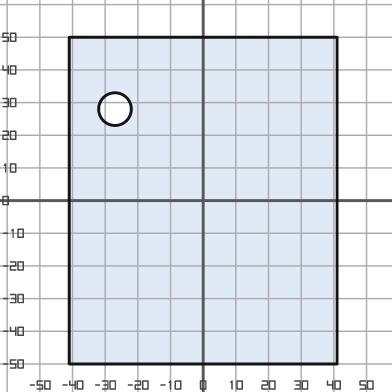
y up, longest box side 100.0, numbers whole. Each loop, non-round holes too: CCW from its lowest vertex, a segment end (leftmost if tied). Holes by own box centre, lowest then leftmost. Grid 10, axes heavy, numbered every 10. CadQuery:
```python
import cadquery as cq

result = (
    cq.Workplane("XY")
    .moveTo(-41.0, -50.0)
    .lineTo(41.0, -50.0)
    .lineTo(41.0, 50.0)
    .lineTo(-41.0, 50.0)
    .close()
    .moveTo(-27.0, 28.0)
    .circle(5.0)
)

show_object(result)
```